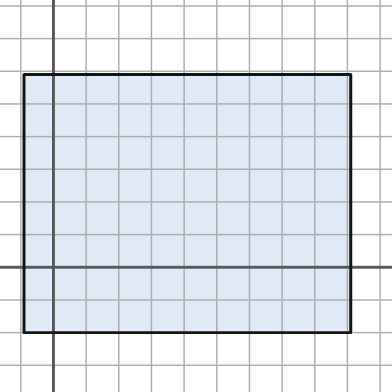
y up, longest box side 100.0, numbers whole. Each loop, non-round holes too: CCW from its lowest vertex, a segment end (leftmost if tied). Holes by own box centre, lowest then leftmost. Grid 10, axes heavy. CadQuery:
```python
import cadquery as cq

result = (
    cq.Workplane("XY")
    .moveTo(-9.0, -20.0)
    .lineTo(91.0, -20.0)
    .lineTo(91.0, 59.0)
    .lineTo(-9.0, 59.0)
    .close()
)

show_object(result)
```